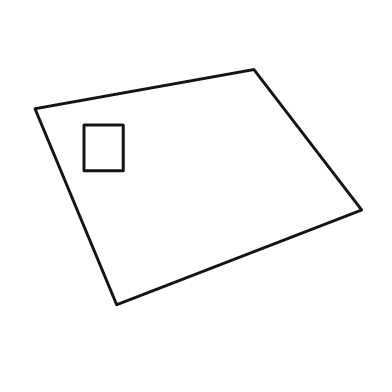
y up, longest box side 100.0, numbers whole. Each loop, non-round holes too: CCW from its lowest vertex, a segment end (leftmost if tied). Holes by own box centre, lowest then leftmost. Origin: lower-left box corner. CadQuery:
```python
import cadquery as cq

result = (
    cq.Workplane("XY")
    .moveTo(25.0, 0.0)
    .lineTo(100.0, 29.0)
    .lineTo(67.0, 72.0)
    .lineTo(0.0, 60.0)
    .close()
    .moveTo(15.0, 41.0)
    .lineTo(27.0, 41.0)
    .lineTo(27.0, 55.0)
    .lineTo(15.0, 55.0)
    .close()
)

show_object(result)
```